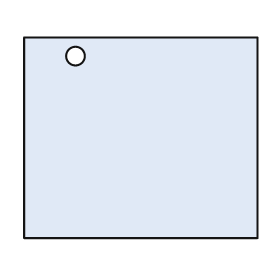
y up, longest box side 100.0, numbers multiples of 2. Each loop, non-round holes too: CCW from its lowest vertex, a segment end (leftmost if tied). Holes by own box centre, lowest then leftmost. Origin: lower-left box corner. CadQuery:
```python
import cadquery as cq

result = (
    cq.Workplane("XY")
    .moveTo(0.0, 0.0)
    .lineTo(100.0, 0.0)
    .lineTo(100.0, 86.0)
    .lineTo(0.0, 86.0)
    .close()
    .moveTo(22.0, 78.0)
    .circle(4.0)
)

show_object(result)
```